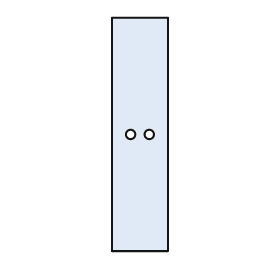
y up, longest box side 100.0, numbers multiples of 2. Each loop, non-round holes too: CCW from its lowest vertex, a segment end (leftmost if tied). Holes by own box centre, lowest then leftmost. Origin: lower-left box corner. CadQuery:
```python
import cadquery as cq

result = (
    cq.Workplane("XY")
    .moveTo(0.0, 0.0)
    .lineTo(24.0, 0.0)
    .lineTo(24.0, 100.0)
    .lineTo(0.0, 100.0)
    .close()
    .moveTo(8.0, 50.0)
    .circle(2.0)
    .moveTo(16.0, 50.0)
    .circle(2.0)
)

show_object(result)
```